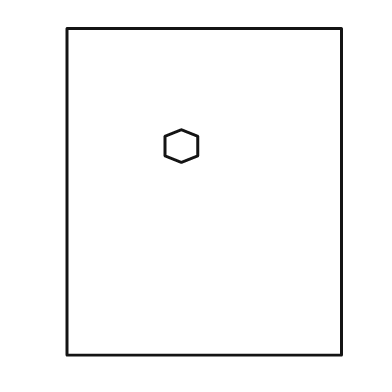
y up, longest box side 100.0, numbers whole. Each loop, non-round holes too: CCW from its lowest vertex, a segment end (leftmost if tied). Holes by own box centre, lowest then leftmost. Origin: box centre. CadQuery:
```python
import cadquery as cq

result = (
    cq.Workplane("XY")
    .moveTo(-42.0, -50.0)
    .lineTo(42.0, -50.0)
    .lineTo(42.0, 50.0)
    .lineTo(-42.0, 50.0)
    .close()
    .moveTo(-7.0, 9.0)
    .lineTo(-2.0, 11.0)
    .lineTo(-2.0, 17.0)
    .lineTo(-7.0, 19.0)
    .lineTo(-12.0, 17.0)
    .lineTo(-12.0, 11.0)
    .close()
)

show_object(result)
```